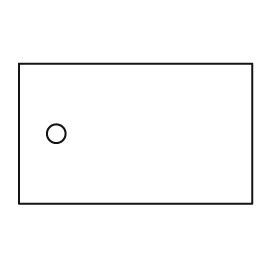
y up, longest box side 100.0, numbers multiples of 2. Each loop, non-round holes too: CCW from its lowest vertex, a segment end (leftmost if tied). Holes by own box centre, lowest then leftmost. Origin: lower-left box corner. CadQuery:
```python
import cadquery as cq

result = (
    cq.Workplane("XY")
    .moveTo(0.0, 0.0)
    .lineTo(100.0, 0.0)
    .lineTo(100.0, 60.0)
    .lineTo(0.0, 60.0)
    .close()
    .moveTo(16.0, 30.0)
    .circle(4.0)
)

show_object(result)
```